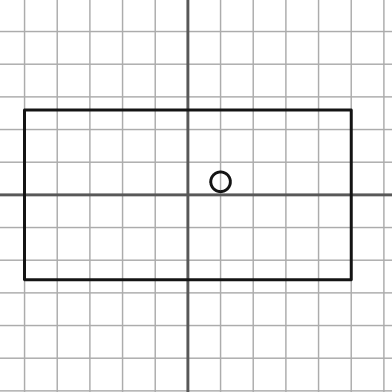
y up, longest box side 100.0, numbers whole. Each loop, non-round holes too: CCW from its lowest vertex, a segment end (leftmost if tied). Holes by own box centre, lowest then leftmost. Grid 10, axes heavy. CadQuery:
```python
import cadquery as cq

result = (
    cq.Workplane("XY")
    .moveTo(-50.0, -26.0)
    .lineTo(50.0, -26.0)
    .lineTo(50.0, 26.0)
    .lineTo(-50.0, 26.0)
    .close()
    .moveTo(10.0, 4.0)
    .circle(3.0)
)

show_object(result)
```